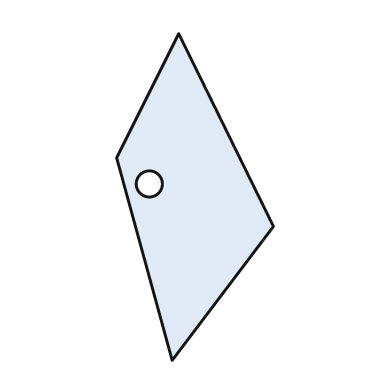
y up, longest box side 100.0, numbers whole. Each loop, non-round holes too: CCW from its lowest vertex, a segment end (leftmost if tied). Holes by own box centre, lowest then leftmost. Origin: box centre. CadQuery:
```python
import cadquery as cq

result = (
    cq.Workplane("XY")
    .moveTo(-7.0, -50.0)
    .lineTo(24.0, -9.0)
    .lineTo(-5.0, 50.0)
    .lineTo(-24.0, 12.0)
    .close()
    .moveTo(-14.0, 4.0)
    .circle(4.0)
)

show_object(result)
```